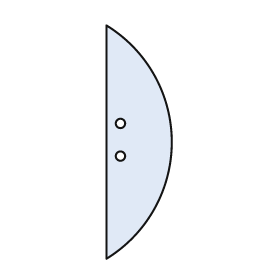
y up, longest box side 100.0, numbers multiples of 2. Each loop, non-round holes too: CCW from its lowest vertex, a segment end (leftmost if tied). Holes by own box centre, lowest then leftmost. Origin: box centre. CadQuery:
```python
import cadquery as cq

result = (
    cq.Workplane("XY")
    .moveTo(-14.0, -50.0)
    .threePointArc((14.0, 0.0), (-14.0, 50.0))
    .close()
    .moveTo(-8.0, -6.0)
    .circle(2.0)
    .moveTo(-8.0, 8.0)
    .circle(2.0)
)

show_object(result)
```